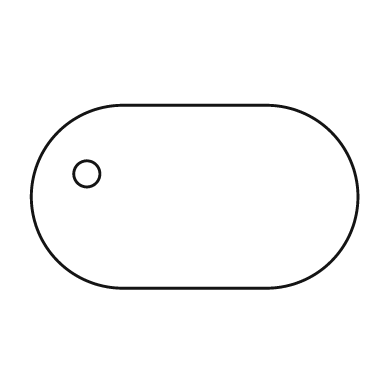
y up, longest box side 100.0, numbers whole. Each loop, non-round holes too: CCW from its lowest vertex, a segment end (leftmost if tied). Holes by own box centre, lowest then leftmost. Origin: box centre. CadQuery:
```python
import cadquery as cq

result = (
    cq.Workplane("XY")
    .moveTo(-22.0, -28.0)
    .lineTo(22.0, -28.0)
    .threePointArc((50.0, 0.0), (22.0, 28.0))
    .lineTo(-22.0, 28.0)
    .threePointArc((-50.0, 0.0), (-22.0, -28.0))
    .close()
    .moveTo(-33.0, 7.0)
    .circle(4.0)
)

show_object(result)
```